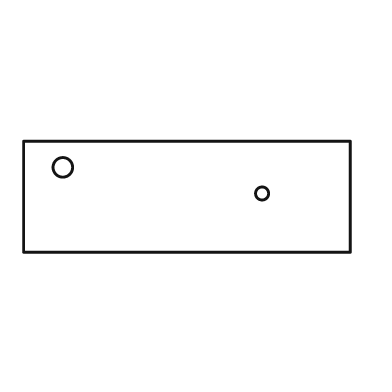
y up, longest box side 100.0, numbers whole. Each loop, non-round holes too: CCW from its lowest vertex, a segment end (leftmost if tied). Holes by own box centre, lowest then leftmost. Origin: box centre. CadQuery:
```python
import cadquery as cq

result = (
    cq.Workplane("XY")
    .moveTo(-50.0, -17.0)
    .lineTo(50.0, -17.0)
    .lineTo(50.0, 17.0)
    .lineTo(-50.0, 17.0)
    .close()
    .moveTo(23.0, 1.0)
    .circle(2.0)
    .moveTo(-38.0, 9.0)
    .circle(3.0)
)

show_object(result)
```